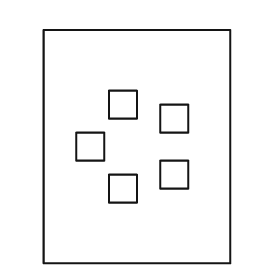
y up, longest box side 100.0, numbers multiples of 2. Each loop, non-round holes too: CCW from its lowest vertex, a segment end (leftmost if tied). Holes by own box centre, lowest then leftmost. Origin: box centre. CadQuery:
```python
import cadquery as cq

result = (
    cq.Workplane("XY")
    .moveTo(-40.0, -50.0)
    .lineTo(40.0, -50.0)
    .lineTo(40.0, 50.0)
    .lineTo(-40.0, 50.0)
    .close()
    .moveTo(-12.0, -24.0)
    .lineTo(0.0, -24.0)
    .lineTo(0.0, -12.0)
    .lineTo(-12.0, -12.0)
    .close()
    .moveTo(10.0, -18.0)
    .lineTo(22.0, -18.0)
    .lineTo(22.0, -6.0)
    .lineTo(10.0, -6.0)
    .close()
    .moveTo(-26.0, -6.0)
    .lineTo(-14.0, -6.0)
    .lineTo(-14.0, 6.0)
    .lineTo(-26.0, 6.0)
    .close()
    .moveTo(10.0, 6.0)
    .lineTo(22.0, 6.0)
    .lineTo(22.0, 18.0)
    .lineTo(10.0, 18.0)
    .close()
    .moveTo(-12.0, 12.0)
    .lineTo(0.0, 12.0)
    .lineTo(0.0, 24.0)
    .lineTo(-12.0, 24.0)
    .close()
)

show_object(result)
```